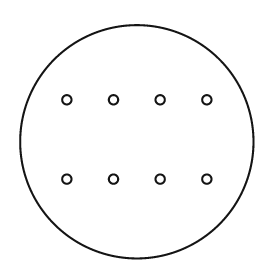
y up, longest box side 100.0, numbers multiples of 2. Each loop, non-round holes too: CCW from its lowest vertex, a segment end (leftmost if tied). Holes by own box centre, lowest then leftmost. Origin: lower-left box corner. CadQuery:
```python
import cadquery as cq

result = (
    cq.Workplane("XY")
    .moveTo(50.0, 50.0)
    .circle(50.0)
    .moveTo(20.0, 34.0)
    .circle(2.0)
    .moveTo(40.0, 34.0)
    .circle(2.0)
    .moveTo(60.0, 34.0)
    .circle(2.0)
    .moveTo(80.0, 34.0)
    .circle(2.0)
    .moveTo(20.0, 68.0)
    .circle(2.0)
    .moveTo(40.0, 68.0)
    .circle(2.0)
    .moveTo(60.0, 68.0)
    .circle(2.0)
    .moveTo(80.0, 68.0)
    .circle(2.0)
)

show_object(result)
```